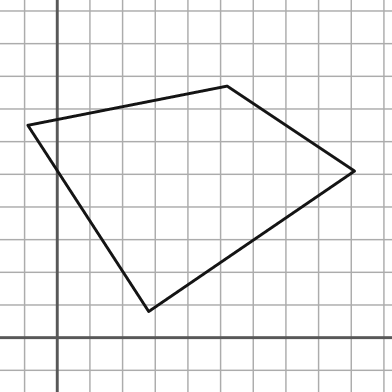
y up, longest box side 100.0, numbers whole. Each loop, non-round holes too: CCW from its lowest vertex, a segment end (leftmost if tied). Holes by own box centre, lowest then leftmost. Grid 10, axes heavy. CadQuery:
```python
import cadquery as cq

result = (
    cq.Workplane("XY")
    .moveTo(28.0, 8.0)
    .lineTo(91.0, 51.0)
    .lineTo(52.0, 77.0)
    .lineTo(-9.0, 65.0)
    .close()
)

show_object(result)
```